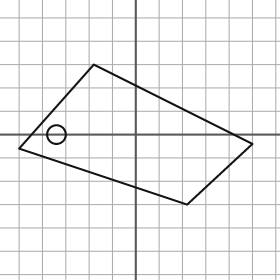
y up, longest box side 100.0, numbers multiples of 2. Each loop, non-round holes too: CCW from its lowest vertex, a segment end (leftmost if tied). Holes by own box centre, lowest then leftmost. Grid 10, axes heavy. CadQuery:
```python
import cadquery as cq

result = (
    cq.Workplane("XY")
    .moveTo(22.0, -30.0)
    .lineTo(50.0, -4.0)
    .lineTo(-18.0, 30.0)
    .lineTo(-50.0, -6.0)
    .close()
    .moveTo(-34.0, 0.0)
    .circle(4.0)
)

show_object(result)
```